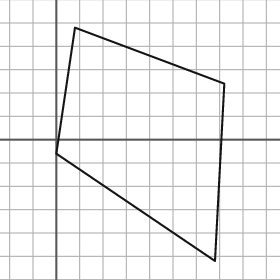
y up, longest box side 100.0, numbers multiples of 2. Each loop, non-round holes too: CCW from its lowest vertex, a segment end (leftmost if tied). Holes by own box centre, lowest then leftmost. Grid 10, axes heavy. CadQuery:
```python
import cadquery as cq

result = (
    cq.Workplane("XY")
    .moveTo(68.0, -52.0)
    .lineTo(72.0, 24.0)
    .lineTo(8.0, 48.0)
    .lineTo(0.0, -6.0)
    .close()
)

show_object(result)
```